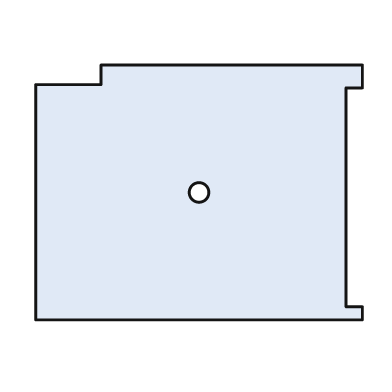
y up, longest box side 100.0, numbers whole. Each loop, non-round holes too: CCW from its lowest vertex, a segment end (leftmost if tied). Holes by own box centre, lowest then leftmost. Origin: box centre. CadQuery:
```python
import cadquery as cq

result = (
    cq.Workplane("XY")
    .moveTo(-50.0, -39.0)
    .lineTo(50.0, -39.0)
    .lineTo(50.0, -35.0)
    .lineTo(45.0, -35.0)
    .lineTo(45.0, 32.0)
    .lineTo(50.0, 32.0)
    .lineTo(50.0, 39.0)
    .lineTo(-30.0, 39.0)
    .lineTo(-30.0, 33.0)
    .lineTo(-50.0, 33.0)
    .close()
    .moveTo(0.0, 0.0)
    .circle(3.0)
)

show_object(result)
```